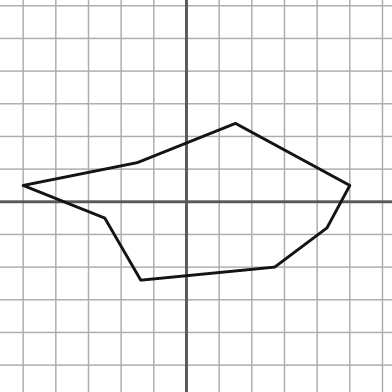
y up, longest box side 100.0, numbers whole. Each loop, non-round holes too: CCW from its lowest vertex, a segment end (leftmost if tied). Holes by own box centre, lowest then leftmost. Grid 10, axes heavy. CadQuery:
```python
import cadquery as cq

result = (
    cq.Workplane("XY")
    .moveTo(-14.0, -24.0)
    .lineTo(27.0, -20.0)
    .lineTo(43.0, -8.0)
    .lineTo(50.0, 5.0)
    .lineTo(15.0, 24.0)
    .lineTo(-15.0, 12.0)
    .lineTo(-50.0, 5.0)
    .lineTo(-25.0, -5.0)
    .close()
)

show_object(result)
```